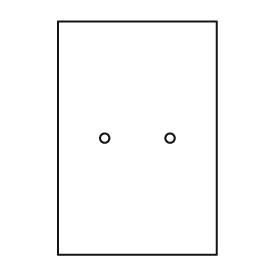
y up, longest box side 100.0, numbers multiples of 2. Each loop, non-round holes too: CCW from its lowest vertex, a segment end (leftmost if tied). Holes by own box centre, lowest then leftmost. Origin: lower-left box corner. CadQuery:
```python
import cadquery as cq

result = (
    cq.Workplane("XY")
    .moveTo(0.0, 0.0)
    .lineTo(68.0, 0.0)
    .lineTo(68.0, 100.0)
    .lineTo(0.0, 100.0)
    .close()
    .moveTo(20.0, 50.0)
    .circle(2.0)
    .moveTo(48.0, 50.0)
    .circle(2.0)
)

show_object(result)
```